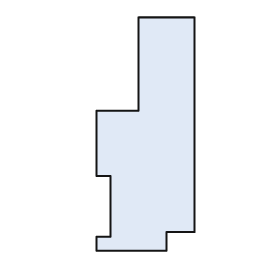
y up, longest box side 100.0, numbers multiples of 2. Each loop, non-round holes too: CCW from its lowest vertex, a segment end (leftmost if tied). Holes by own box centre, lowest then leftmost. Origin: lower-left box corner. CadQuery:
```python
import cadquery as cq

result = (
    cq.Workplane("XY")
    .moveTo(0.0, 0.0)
    .lineTo(30.0, 0.0)
    .lineTo(30.0, 8.0)
    .lineTo(42.0, 8.0)
    .lineTo(42.0, 100.0)
    .lineTo(18.0, 100.0)
    .lineTo(18.0, 60.0)
    .lineTo(0.0, 60.0)
    .lineTo(0.0, 32.0)
    .lineTo(6.0, 32.0)
    .lineTo(6.0, 6.0)
    .lineTo(0.0, 6.0)
    .close()
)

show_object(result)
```